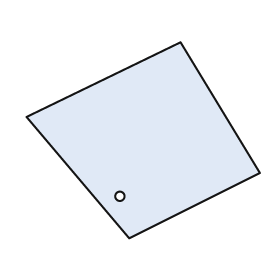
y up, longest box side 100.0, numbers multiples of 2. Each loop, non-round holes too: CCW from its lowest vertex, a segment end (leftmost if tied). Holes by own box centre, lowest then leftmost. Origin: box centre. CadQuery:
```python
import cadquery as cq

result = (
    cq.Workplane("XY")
    .moveTo(-6.0, -42.0)
    .lineTo(50.0, -14.0)
    .lineTo(16.0, 42.0)
    .lineTo(-50.0, 10.0)
    .close()
    .moveTo(-10.0, -24.0)
    .circle(2.0)
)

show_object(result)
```